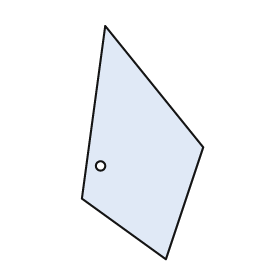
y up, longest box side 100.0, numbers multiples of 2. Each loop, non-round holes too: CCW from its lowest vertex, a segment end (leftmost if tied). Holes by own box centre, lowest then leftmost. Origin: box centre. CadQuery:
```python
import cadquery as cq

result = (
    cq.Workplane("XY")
    .moveTo(10.0, -50.0)
    .lineTo(26.0, -2.0)
    .lineTo(-16.0, 50.0)
    .lineTo(-26.0, -24.0)
    .close()
    .moveTo(-18.0, -10.0)
    .circle(2.0)
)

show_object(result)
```